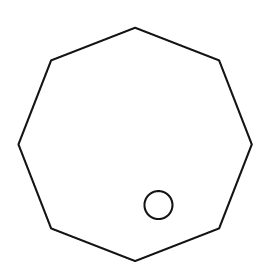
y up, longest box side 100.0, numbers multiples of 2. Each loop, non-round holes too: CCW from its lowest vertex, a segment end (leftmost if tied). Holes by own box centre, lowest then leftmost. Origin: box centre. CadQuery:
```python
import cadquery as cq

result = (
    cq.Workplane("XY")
    .moveTo(0.0, -50.0)
    .lineTo(36.0, -36.0)
    .lineTo(50.0, 0.0)
    .lineTo(36.0, 36.0)
    .lineTo(0.0, 50.0)
    .lineTo(-36.0, 36.0)
    .lineTo(-50.0, 0.0)
    .lineTo(-36.0, -36.0)
    .close()
    .moveTo(10.0, -26.0)
    .circle(6.0)
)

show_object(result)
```